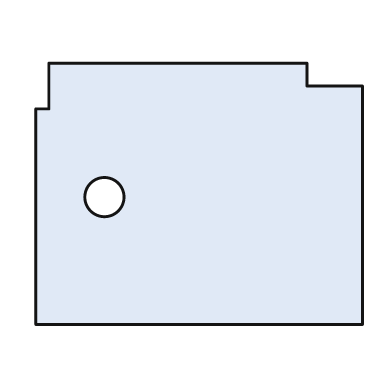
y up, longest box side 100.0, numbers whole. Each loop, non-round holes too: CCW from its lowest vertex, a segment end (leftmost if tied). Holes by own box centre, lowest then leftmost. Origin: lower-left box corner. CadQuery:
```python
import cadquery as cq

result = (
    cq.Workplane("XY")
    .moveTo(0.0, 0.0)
    .lineTo(100.0, 0.0)
    .lineTo(100.0, 73.0)
    .lineTo(83.0, 73.0)
    .lineTo(83.0, 80.0)
    .lineTo(4.0, 80.0)
    .lineTo(4.0, 66.0)
    .lineTo(0.0, 66.0)
    .close()
    .moveTo(21.0, 39.0)
    .circle(6.0)
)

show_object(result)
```